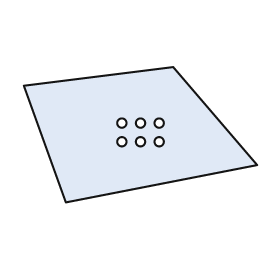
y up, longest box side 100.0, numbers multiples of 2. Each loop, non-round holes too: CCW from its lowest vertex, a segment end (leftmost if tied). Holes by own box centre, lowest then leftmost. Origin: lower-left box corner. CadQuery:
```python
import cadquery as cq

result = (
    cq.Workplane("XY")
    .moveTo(18.0, 0.0)
    .lineTo(100.0, 16.0)
    .lineTo(64.0, 58.0)
    .lineTo(0.0, 50.0)
    .close()
    .moveTo(42.0, 26.0)
    .circle(2.0)
    .moveTo(50.0, 26.0)
    .circle(2.0)
    .moveTo(58.0, 26.0)
    .circle(2.0)
    .moveTo(42.0, 34.0)
    .circle(2.0)
    .moveTo(50.0, 34.0)
    .circle(2.0)
    .moveTo(58.0, 34.0)
    .circle(2.0)
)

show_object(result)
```